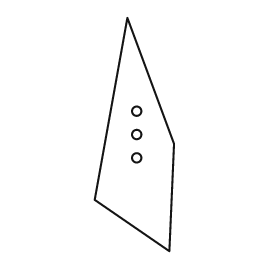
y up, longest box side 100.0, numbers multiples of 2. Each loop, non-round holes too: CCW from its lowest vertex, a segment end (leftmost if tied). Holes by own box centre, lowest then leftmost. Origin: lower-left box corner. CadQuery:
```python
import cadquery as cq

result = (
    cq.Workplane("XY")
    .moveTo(32.0, 0.0)
    .lineTo(34.0, 46.0)
    .lineTo(14.0, 100.0)
    .lineTo(0.0, 22.0)
    .close()
    .moveTo(18.0, 40.0)
    .circle(2.0)
    .moveTo(18.0, 50.0)
    .circle(2.0)
    .moveTo(18.0, 60.0)
    .circle(2.0)
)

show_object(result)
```